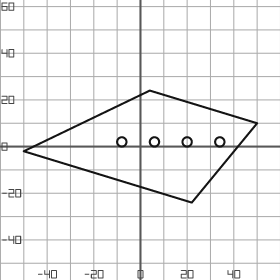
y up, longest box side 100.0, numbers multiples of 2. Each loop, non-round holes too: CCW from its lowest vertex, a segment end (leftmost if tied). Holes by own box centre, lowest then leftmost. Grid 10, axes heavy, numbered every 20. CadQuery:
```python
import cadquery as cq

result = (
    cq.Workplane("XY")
    .moveTo(22.0, -24.0)
    .lineTo(50.0, 10.0)
    .lineTo(4.0, 24.0)
    .lineTo(-50.0, -2.0)
    .close()
    .moveTo(-8.0, 2.0)
    .circle(2.0)
    .moveTo(6.0, 2.0)
    .circle(2.0)
    .moveTo(20.0, 2.0)
    .circle(2.0)
    .moveTo(34.0, 2.0)
    .circle(2.0)
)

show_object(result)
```